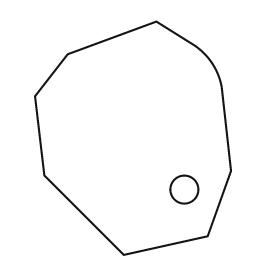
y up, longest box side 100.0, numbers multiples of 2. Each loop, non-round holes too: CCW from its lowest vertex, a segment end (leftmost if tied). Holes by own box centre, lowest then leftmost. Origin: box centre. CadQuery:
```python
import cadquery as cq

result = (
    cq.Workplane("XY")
    .moveTo(-4.0, -50.0)
    .lineTo(32.0, -42.0)
    .lineTo(42.0, -14.0)
    .lineTo(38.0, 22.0)
    .threePointArc((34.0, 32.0), (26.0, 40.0))
    .lineTo(10.0, 50.0)
    .lineTo(-28.0, 36.0)
    .lineTo(-42.0, 18.0)
    .lineTo(-38.0, -16.0)
    .close()
    .moveTo(22.0, -22.0)
    .circle(6.0)
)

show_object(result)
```